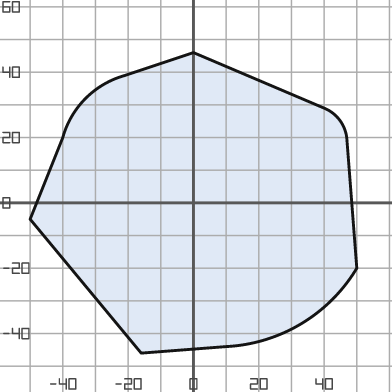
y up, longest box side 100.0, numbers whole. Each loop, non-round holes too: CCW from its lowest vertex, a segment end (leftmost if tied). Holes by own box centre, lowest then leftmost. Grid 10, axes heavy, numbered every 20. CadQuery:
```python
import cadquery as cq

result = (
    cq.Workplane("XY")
    .moveTo(-16.0, -46.0)
    .lineTo(10.0, -44.0)
    .threePointArc((33.0, -37.0), (50.0, -20.0))
    .lineTo(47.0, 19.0)
    .threePointArc((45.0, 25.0), (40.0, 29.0))
    .lineTo(0.0, 46.0)
    .lineTo(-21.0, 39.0)
    .threePointArc((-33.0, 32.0), (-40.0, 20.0))
    .lineTo(-50.0, -5.0)
    .close()
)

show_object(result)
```